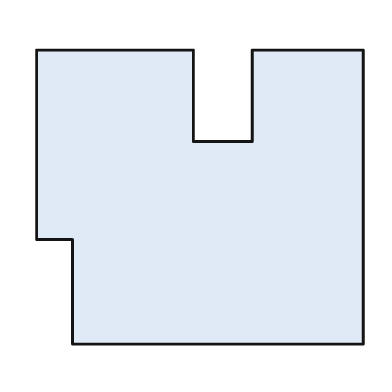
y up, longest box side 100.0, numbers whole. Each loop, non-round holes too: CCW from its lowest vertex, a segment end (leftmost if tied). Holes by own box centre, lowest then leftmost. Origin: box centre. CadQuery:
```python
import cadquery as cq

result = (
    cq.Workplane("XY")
    .moveTo(-39.0, -45.0)
    .lineTo(50.0, -45.0)
    .lineTo(50.0, 45.0)
    .lineTo(16.0, 45.0)
    .lineTo(16.0, 17.0)
    .lineTo(-2.0, 17.0)
    .lineTo(-2.0, 45.0)
    .lineTo(-50.0, 45.0)
    .lineTo(-50.0, -13.0)
    .lineTo(-39.0, -13.0)
    .close()
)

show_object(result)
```